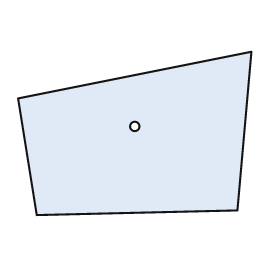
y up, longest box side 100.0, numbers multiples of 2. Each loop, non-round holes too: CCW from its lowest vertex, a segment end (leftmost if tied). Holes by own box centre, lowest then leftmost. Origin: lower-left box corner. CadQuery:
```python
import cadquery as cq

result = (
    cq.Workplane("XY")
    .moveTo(8.0, 0.0)
    .lineTo(94.0, 2.0)
    .lineTo(100.0, 70.0)
    .lineTo(0.0, 50.0)
    .close()
    .moveTo(50.0, 38.0)
    .circle(2.0)
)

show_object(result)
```